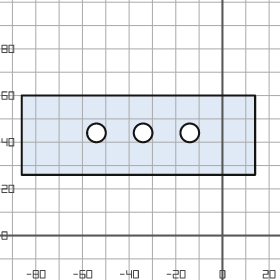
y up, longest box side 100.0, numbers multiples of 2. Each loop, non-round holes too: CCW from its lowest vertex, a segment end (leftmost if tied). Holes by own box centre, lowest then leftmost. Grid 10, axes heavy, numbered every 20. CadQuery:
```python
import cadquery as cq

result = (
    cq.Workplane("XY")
    .moveTo(-86.0, 26.0)
    .lineTo(14.0, 26.0)
    .lineTo(14.0, 60.0)
    .lineTo(-86.0, 60.0)
    .close()
    .moveTo(-54.0, 44.0)
    .circle(4.0)
    .moveTo(-34.0, 44.0)
    .circle(4.0)
    .moveTo(-14.0, 44.0)
    .circle(4.0)
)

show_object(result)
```